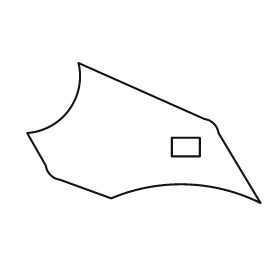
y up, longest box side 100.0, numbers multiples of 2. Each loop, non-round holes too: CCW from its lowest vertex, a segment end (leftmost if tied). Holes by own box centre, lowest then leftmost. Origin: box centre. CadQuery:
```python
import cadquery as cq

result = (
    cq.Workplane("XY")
    .moveTo(50.0, -30.0)
    .lineTo(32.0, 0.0)
    .threePointArc((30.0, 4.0), (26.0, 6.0))
    .lineTo(-28.0, 30.0)
    .threePointArc((-32.0, 10.0), (-50.0, 0.0))
    .lineTo(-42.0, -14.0)
    .threePointArc((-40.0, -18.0), (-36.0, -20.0))
    .lineTo(-14.0, -28.0)
    .threePointArc((18.0, -22.0), (50.0, -30.0))
    .close()
    .moveTo(12.0, -10.0)
    .lineTo(24.0, -10.0)
    .lineTo(24.0, -2.0)
    .lineTo(12.0, -2.0)
    .close()
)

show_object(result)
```